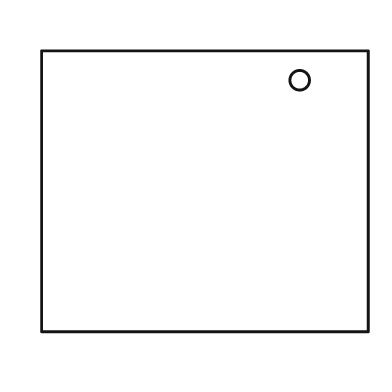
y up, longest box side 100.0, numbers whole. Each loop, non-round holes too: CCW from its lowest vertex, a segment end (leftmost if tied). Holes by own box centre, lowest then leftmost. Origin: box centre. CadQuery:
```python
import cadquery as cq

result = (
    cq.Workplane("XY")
    .moveTo(-50.0, -43.0)
    .lineTo(50.0, -43.0)
    .lineTo(50.0, 43.0)
    .lineTo(-50.0, 43.0)
    .close()
    .moveTo(29.0, 34.0)
    .circle(3.0)
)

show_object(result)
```